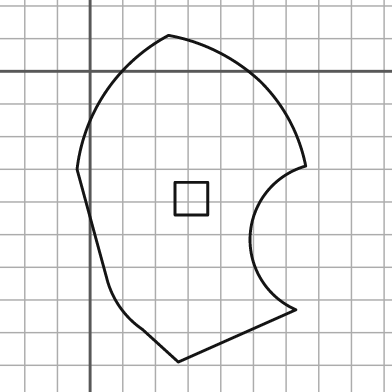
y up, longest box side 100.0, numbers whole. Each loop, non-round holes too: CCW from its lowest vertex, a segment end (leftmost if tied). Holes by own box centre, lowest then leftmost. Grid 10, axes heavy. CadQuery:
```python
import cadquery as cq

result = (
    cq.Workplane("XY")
    .moveTo(27.0, -89.0)
    .lineTo(63.0, -73.0)
    .threePointArc((49.0, -50.0), (66.0, -29.0))
    .threePointArc((61.0, -15.0), (52.0, -3.0))
    .threePointArc((39.0, 6.0), (24.0, 11.0))
    .threePointArc((5.0, -6.0), (-4.0, -30.0))
    .lineTo(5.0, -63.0)
    .threePointArc((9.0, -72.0), (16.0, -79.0))
    .close()
    .moveTo(26.0, -44.0)
    .lineTo(36.0, -44.0)
    .lineTo(36.0, -34.0)
    .lineTo(26.0, -34.0)
    .close()
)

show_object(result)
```